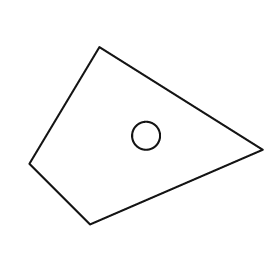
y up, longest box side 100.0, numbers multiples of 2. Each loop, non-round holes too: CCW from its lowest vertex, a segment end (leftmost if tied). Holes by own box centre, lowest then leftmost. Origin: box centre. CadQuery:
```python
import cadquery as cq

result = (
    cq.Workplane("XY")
    .moveTo(-24.0, -38.0)
    .lineTo(50.0, -6.0)
    .lineTo(-20.0, 38.0)
    .lineTo(-50.0, -12.0)
    .close()
    .moveTo(0.0, 0.0)
    .circle(6.0)
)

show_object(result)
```